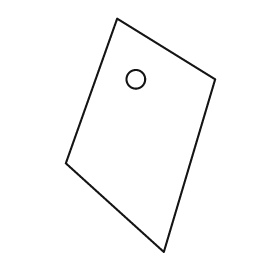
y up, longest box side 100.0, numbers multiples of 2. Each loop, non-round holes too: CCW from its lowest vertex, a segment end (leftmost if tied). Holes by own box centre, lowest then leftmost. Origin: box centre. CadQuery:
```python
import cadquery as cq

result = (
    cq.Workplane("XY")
    .moveTo(10.0, -50.0)
    .lineTo(32.0, 24.0)
    .lineTo(-10.0, 50.0)
    .lineTo(-32.0, -12.0)
    .close()
    .moveTo(-2.0, 24.0)
    .circle(4.0)
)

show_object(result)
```